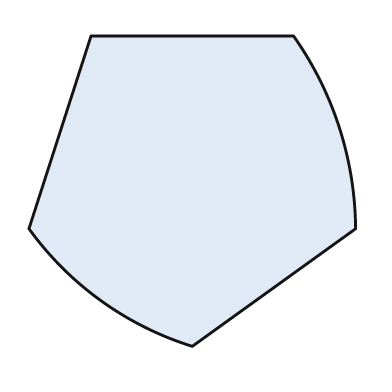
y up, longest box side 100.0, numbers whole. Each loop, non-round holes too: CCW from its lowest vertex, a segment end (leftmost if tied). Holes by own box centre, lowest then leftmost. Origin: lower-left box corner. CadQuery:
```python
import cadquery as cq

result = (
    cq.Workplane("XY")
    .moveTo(50.0, 0.0)
    .lineTo(100.0, 36.0)
    .threePointArc((95.0, 67.0), (81.0, 95.0))
    .lineTo(19.0, 95.0)
    .lineTo(0.0, 36.0)
    .threePointArc((22.0, 14.0), (50.0, 0.0))
    .close()
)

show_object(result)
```